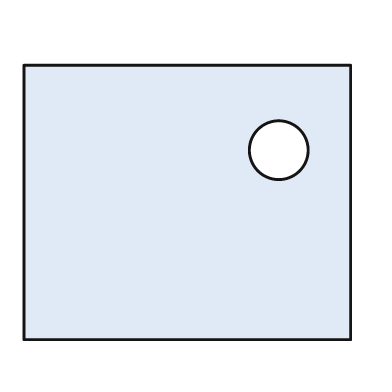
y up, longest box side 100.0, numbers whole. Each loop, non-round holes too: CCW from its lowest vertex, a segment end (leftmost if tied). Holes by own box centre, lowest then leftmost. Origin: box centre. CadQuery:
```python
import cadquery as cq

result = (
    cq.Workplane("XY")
    .moveTo(-50.0, -42.0)
    .lineTo(50.0, -42.0)
    .lineTo(50.0, 42.0)
    .lineTo(-50.0, 42.0)
    .close()
    .moveTo(28.0, 16.0)
    .circle(9.0)
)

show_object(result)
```